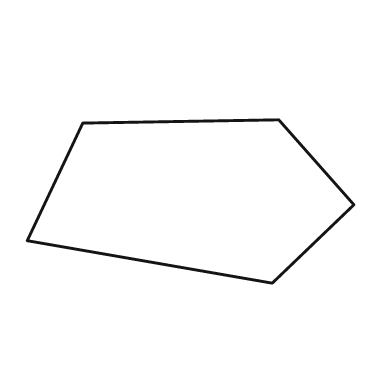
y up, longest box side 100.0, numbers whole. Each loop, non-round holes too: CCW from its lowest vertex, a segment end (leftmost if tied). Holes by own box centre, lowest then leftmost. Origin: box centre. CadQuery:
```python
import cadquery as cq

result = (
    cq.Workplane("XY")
    .moveTo(25.0, -25.0)
    .lineTo(50.0, -1.0)
    .lineTo(27.0, 25.0)
    .lineTo(-33.0, 24.0)
    .lineTo(-50.0, -12.0)
    .close()
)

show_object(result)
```